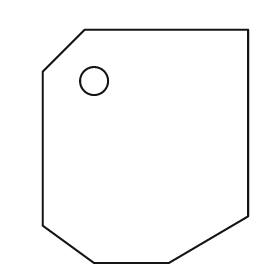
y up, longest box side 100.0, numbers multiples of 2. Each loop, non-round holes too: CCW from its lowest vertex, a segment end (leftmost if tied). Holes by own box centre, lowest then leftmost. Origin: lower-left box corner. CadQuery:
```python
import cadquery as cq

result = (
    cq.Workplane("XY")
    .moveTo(22.0, 0.0)
    .lineTo(54.0, 0.0)
    .lineTo(88.0, 20.0)
    .lineTo(88.0, 100.0)
    .lineTo(18.0, 100.0)
    .lineTo(0.0, 82.0)
    .lineTo(0.0, 16.0)
    .close()
    .moveTo(22.0, 78.0)
    .circle(6.0)
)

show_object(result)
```